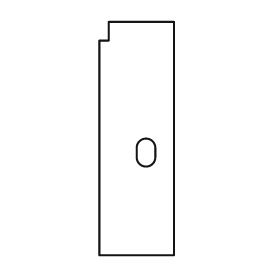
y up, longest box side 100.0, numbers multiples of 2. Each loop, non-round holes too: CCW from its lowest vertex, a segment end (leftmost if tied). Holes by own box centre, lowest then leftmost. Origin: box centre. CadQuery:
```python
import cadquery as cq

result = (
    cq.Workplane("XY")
    .moveTo(-16.0, -50.0)
    .lineTo(16.0, -50.0)
    .lineTo(16.0, 50.0)
    .lineTo(-12.0, 50.0)
    .lineTo(-12.0, 42.0)
    .lineTo(-16.0, 42.0)
    .close()
    .moveTo(0.0, -8.0)
    .threePointArc((4.0, -12.0), (8.0, -8.0))
    .lineTo(8.0, -4.0)
    .threePointArc((4.0, 0.0), (0.0, -4.0))
    .close()
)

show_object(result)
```